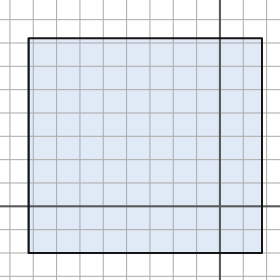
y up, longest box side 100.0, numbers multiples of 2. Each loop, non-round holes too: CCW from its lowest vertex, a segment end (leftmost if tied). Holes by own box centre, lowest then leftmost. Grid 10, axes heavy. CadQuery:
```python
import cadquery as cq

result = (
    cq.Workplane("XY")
    .moveTo(-82.0, -20.0)
    .lineTo(18.0, -20.0)
    .lineTo(18.0, 72.0)
    .lineTo(-82.0, 72.0)
    .close()
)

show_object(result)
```